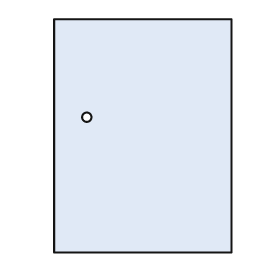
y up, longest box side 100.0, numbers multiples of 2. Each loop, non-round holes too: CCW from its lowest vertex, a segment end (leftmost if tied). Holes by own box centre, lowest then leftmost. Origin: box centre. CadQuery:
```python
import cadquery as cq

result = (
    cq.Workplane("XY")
    .moveTo(-38.0, -50.0)
    .lineTo(38.0, -50.0)
    .lineTo(38.0, 50.0)
    .lineTo(-38.0, 50.0)
    .close()
    .moveTo(-24.0, 8.0)
    .circle(2.0)
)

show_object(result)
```